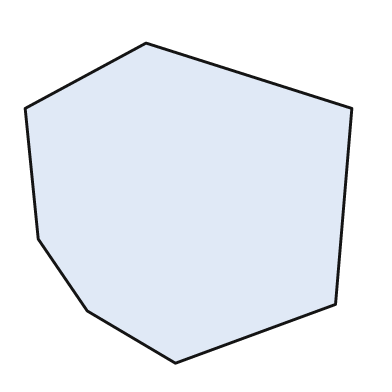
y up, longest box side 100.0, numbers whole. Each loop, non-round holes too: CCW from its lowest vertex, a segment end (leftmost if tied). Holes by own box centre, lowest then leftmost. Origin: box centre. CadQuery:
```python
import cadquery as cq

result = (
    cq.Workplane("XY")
    .moveTo(-4.0, -49.0)
    .lineTo(45.0, -31.0)
    .lineTo(50.0, 29.0)
    .lineTo(-13.0, 49.0)
    .lineTo(-50.0, 29.0)
    .lineTo(-46.0, -11.0)
    .lineTo(-31.0, -33.0)
    .close()
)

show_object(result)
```